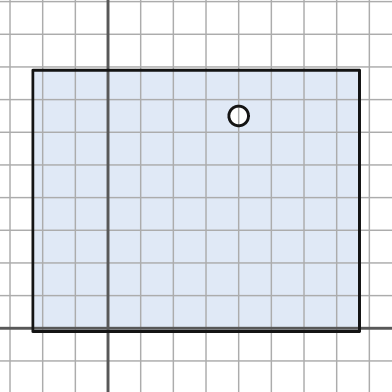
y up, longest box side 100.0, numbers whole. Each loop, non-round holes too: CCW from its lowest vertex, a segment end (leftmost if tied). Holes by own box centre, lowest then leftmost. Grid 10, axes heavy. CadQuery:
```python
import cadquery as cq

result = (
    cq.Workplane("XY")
    .moveTo(-23.0, -1.0)
    .lineTo(77.0, -1.0)
    .lineTo(77.0, 79.0)
    .lineTo(-23.0, 79.0)
    .close()
    .moveTo(40.0, 65.0)
    .circle(3.0)
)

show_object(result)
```